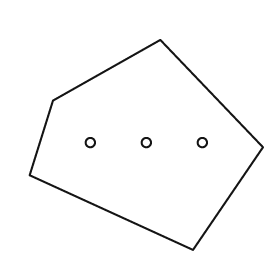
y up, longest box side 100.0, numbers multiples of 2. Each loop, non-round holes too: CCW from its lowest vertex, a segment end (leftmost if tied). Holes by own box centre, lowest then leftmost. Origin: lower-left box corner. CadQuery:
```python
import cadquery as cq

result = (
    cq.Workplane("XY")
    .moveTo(70.0, 0.0)
    .lineTo(100.0, 44.0)
    .lineTo(56.0, 90.0)
    .lineTo(10.0, 64.0)
    .lineTo(0.0, 32.0)
    .close()
    .moveTo(26.0, 46.0)
    .circle(2.0)
    .moveTo(50.0, 46.0)
    .circle(2.0)
    .moveTo(74.0, 46.0)
    .circle(2.0)
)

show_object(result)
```